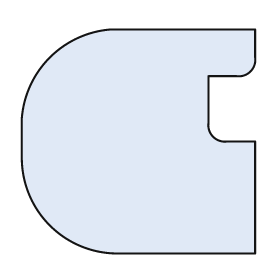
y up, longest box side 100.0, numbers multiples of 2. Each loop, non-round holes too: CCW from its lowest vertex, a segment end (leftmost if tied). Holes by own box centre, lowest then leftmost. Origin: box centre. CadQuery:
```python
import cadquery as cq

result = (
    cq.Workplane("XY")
    .moveTo(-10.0, -48.0)
    .lineTo(50.0, -48.0)
    .lineTo(50.0, 0.0)
    .lineTo(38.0, 0.0)
    .threePointArc((32.0, 2.0), (30.0, 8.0))
    .lineTo(30.0, 28.0)
    .lineTo(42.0, 28.0)
    .threePointArc((48.0, 30.0), (50.0, 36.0))
    .lineTo(50.0, 48.0)
    .lineTo(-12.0, 48.0)
    .threePointArc((-38.0, 36.0), (-50.0, 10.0))
    .lineTo(-50.0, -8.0)
    .threePointArc((-38.0, -36.0), (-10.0, -48.0))
    .close()
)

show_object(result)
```